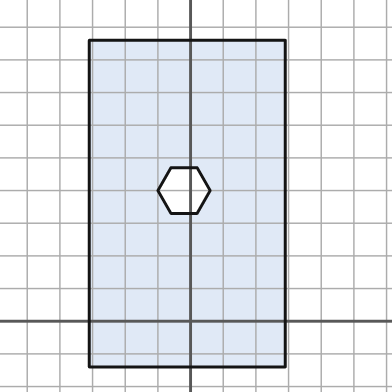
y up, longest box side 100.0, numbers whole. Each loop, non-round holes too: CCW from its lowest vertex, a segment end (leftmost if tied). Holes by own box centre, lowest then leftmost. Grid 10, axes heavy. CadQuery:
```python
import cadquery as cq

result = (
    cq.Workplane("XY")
    .moveTo(-31.0, -14.0)
    .lineTo(29.0, -14.0)
    .lineTo(29.0, 86.0)
    .lineTo(-31.0, 86.0)
    .close()
    .moveTo(-6.0, 33.0)
    .lineTo(2.0, 33.0)
    .lineTo(6.0, 40.0)
    .lineTo(2.0, 47.0)
    .lineTo(-6.0, 47.0)
    .lineTo(-10.0, 40.0)
    .close()
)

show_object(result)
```